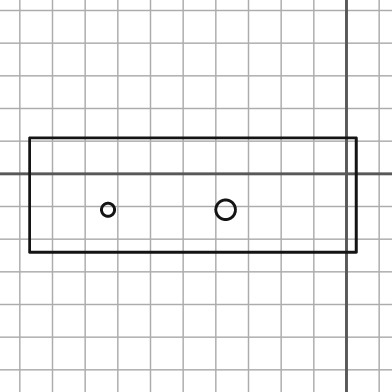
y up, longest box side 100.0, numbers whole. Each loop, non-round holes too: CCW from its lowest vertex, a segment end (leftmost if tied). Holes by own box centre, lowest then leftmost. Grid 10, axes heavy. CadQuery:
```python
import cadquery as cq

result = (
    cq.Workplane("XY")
    .moveTo(-97.0, -24.0)
    .lineTo(3.0, -24.0)
    .lineTo(3.0, 11.0)
    .lineTo(-97.0, 11.0)
    .close()
    .moveTo(-73.0, -11.0)
    .circle(2.0)
    .moveTo(-37.0, -11.0)
    .circle(3.0)
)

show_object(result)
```